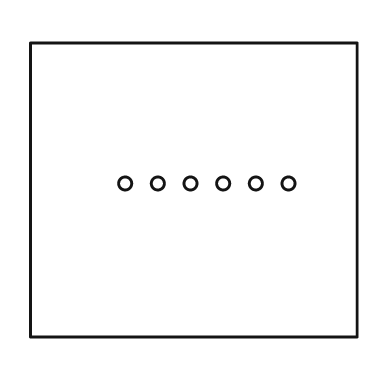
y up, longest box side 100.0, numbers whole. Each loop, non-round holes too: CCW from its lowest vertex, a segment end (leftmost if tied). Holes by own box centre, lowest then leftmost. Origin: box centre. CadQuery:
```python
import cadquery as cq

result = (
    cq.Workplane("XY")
    .moveTo(-50.0, -45.0)
    .lineTo(50.0, -45.0)
    .lineTo(50.0, 45.0)
    .lineTo(-50.0, 45.0)
    .close()
    .moveTo(-21.0, 2.0)
    .circle(2.0)
    .moveTo(-11.0, 2.0)
    .circle(2.0)
    .moveTo(-1.0, 2.0)
    .circle(2.0)
    .moveTo(9.0, 2.0)
    .circle(2.0)
    .moveTo(19.0, 2.0)
    .circle(2.0)
    .moveTo(29.0, 2.0)
    .circle(2.0)
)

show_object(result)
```